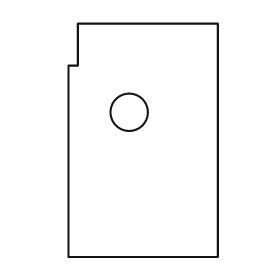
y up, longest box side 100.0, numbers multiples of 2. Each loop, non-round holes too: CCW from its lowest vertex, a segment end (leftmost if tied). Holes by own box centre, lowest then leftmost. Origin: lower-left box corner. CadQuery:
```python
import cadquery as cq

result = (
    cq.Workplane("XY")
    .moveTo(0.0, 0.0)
    .lineTo(64.0, 0.0)
    .lineTo(64.0, 100.0)
    .lineTo(4.0, 100.0)
    .lineTo(4.0, 82.0)
    .lineTo(0.0, 82.0)
    .close()
    .moveTo(26.0, 62.0)
    .circle(8.0)
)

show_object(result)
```